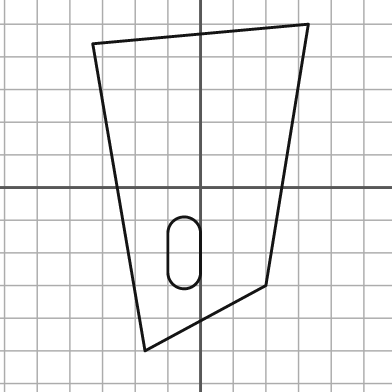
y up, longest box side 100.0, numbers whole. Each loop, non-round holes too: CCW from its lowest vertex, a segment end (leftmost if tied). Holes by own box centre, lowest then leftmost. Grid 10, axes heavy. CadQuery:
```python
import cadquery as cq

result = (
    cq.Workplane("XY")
    .moveTo(-17.0, -50.0)
    .lineTo(20.0, -30.0)
    .lineTo(33.0, 50.0)
    .lineTo(-33.0, 44.0)
    .close()
    .moveTo(-10.0, -26.0)
    .threePointArc((-5.0, -31.0), (0.0, -26.0))
    .lineTo(0.0, -14.0)
    .threePointArc((-5.0, -9.0), (-10.0, -14.0))
    .close()
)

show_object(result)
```